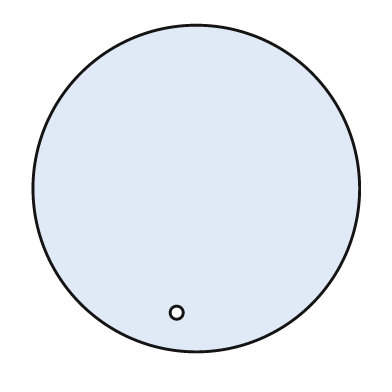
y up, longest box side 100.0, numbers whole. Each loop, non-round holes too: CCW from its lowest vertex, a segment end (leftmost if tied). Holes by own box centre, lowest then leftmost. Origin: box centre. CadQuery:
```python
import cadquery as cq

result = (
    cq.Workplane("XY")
    .moveTo(0.0, 0.0)
    .circle(50.0)
    .moveTo(-6.0, -38.0)
    .circle(2.0)
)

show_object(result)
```